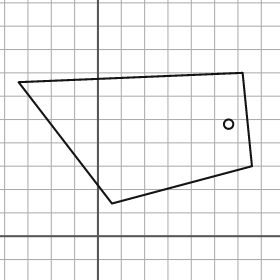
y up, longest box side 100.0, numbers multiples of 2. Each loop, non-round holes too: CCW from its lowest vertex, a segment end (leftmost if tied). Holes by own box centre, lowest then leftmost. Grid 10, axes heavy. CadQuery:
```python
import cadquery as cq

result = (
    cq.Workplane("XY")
    .moveTo(6.0, 14.0)
    .lineTo(66.0, 30.0)
    .lineTo(62.0, 70.0)
    .lineTo(-34.0, 66.0)
    .close()
    .moveTo(56.0, 48.0)
    .circle(2.0)
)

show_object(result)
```